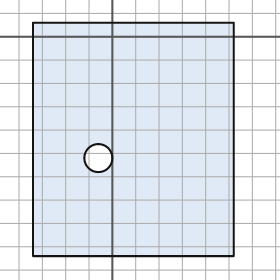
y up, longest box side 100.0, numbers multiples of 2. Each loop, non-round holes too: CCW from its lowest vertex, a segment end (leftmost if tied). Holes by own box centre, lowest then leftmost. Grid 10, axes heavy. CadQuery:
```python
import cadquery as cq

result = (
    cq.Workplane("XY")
    .moveTo(-34.0, -94.0)
    .lineTo(52.0, -94.0)
    .lineTo(52.0, 6.0)
    .lineTo(-34.0, 6.0)
    .close()
    .moveTo(-6.0, -52.0)
    .circle(6.0)
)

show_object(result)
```